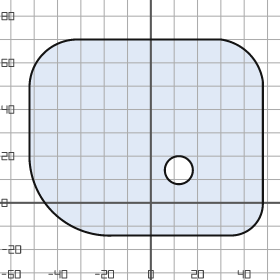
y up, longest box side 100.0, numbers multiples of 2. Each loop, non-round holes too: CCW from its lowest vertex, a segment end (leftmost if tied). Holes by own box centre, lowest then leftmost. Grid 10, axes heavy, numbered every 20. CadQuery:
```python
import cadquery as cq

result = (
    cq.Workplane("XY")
    .moveTo(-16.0, -14.0)
    .lineTo(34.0, -14.0)
    .threePointArc((44.0, -10.0), (48.0, 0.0))
    .lineTo(48.0, 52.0)
    .threePointArc((42.0, 64.0), (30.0, 70.0))
    .lineTo(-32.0, 70.0)
    .threePointArc((-46.0, 64.0), (-52.0, 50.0))
    .lineTo(-52.0, 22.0)
    .threePointArc((-42.0, -4.0), (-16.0, -14.0))
    .close()
    .moveTo(12.0, 14.0)
    .circle(6.0)
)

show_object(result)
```